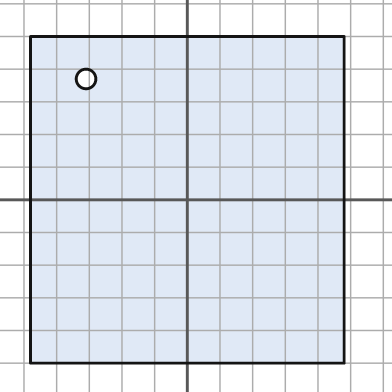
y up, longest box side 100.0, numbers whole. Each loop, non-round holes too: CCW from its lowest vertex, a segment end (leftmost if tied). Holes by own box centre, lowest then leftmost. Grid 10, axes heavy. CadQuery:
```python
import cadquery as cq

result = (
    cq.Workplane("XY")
    .moveTo(-48.0, -50.0)
    .lineTo(48.0, -50.0)
    .lineTo(48.0, 50.0)
    .lineTo(-48.0, 50.0)
    .close()
    .moveTo(-31.0, 37.0)
    .circle(3.0)
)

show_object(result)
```